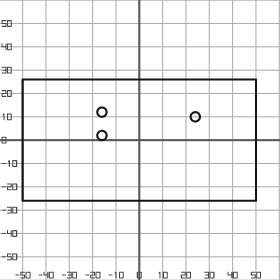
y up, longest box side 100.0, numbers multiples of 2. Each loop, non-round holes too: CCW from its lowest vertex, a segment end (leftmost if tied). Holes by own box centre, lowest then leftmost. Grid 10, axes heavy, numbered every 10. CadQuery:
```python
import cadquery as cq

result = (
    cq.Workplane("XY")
    .moveTo(-50.0, -26.0)
    .lineTo(50.0, -26.0)
    .lineTo(50.0, 26.0)
    .lineTo(-50.0, 26.0)
    .close()
    .moveTo(-16.0, 2.0)
    .circle(2.0)
    .moveTo(24.0, 10.0)
    .circle(2.0)
    .moveTo(-16.0, 12.0)
    .circle(2.0)
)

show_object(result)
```